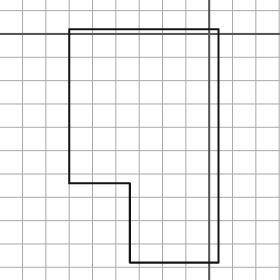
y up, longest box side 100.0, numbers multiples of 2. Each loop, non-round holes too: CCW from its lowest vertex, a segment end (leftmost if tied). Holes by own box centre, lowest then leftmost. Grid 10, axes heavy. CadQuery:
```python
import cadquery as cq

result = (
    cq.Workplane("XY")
    .moveTo(-34.0, -98.0)
    .lineTo(4.0, -98.0)
    .lineTo(4.0, 2.0)
    .lineTo(-60.0, 2.0)
    .lineTo(-60.0, -64.0)
    .lineTo(-34.0, -64.0)
    .close()
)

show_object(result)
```